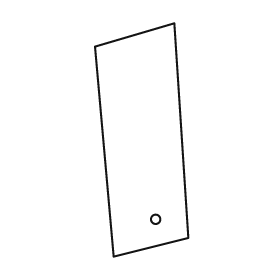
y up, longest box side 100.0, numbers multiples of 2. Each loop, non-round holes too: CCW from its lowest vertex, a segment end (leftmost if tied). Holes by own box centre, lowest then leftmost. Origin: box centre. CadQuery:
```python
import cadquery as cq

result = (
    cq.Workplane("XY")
    .moveTo(-12.0, -50.0)
    .lineTo(20.0, -42.0)
    .lineTo(14.0, 50.0)
    .lineTo(-20.0, 40.0)
    .close()
    .moveTo(6.0, -34.0)
    .circle(2.0)
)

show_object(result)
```